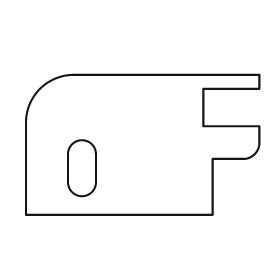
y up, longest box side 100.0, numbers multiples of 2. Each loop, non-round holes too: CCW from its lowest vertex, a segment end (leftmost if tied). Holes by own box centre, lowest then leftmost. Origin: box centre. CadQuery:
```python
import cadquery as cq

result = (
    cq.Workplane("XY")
    .moveTo(-50.0, -30.0)
    .lineTo(30.0, -30.0)
    .lineTo(30.0, -6.0)
    .lineTo(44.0, -6.0)
    .threePointArc((48.0, -4.0), (50.0, 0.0))
    .lineTo(50.0, 8.0)
    .lineTo(26.0, 8.0)
    .lineTo(26.0, 24.0)
    .lineTo(50.0, 24.0)
    .lineTo(50.0, 30.0)
    .lineTo(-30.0, 30.0)
    .threePointArc((-44.0, 24.0), (-50.0, 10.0))
    .close()
    .moveTo(-32.0, -16.0)
    .threePointArc((-26.0, -22.0), (-20.0, -16.0))
    .lineTo(-20.0, -4.0)
    .threePointArc((-26.0, 2.0), (-32.0, -4.0))
    .close()
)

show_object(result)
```